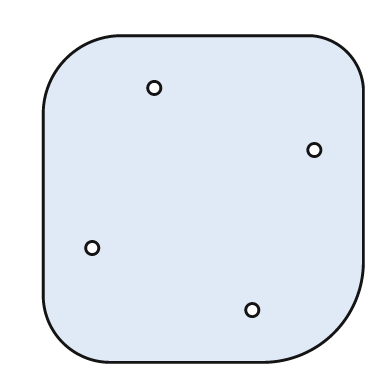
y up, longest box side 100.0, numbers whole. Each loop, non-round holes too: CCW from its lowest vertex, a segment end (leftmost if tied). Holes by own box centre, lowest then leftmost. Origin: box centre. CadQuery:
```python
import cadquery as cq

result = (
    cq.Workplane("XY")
    .moveTo(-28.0, -50.0)
    .lineTo(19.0, -50.0)
    .threePointArc((40.0, -41.0), (49.0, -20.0))
    .lineTo(49.0, 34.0)
    .threePointArc((44.0, 45.0), (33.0, 50.0))
    .lineTo(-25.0, 50.0)
    .threePointArc((-42.0, 43.0), (-49.0, 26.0))
    .lineTo(-49.0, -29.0)
    .threePointArc((-43.0, -44.0), (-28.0, -50.0))
    .close()
    .moveTo(15.0, -34.0)
    .circle(2.0)
    .moveTo(-34.0, -15.0)
    .circle(2.0)
    .moveTo(34.0, 15.0)
    .circle(2.0)
    .moveTo(-15.0, 34.0)
    .circle(2.0)
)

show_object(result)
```